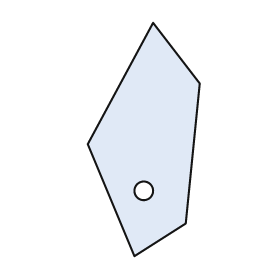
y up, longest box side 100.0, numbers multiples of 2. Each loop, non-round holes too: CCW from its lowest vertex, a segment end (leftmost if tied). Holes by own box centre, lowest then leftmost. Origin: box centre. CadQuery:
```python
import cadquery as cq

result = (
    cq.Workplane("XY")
    .moveTo(-4.0, -50.0)
    .lineTo(18.0, -36.0)
    .lineTo(24.0, 24.0)
    .lineTo(4.0, 50.0)
    .lineTo(-24.0, -2.0)
    .close()
    .moveTo(0.0, -22.0)
    .circle(4.0)
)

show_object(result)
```